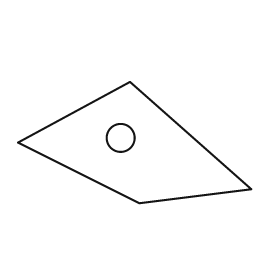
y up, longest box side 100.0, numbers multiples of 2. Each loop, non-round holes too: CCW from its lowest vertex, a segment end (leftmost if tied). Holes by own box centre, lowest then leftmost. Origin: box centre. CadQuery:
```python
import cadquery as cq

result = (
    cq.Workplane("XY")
    .moveTo(2.0, -26.0)
    .lineTo(50.0, -20.0)
    .lineTo(-2.0, 26.0)
    .lineTo(-50.0, 0.0)
    .close()
    .moveTo(-6.0, 2.0)
    .circle(6.0)
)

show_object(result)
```